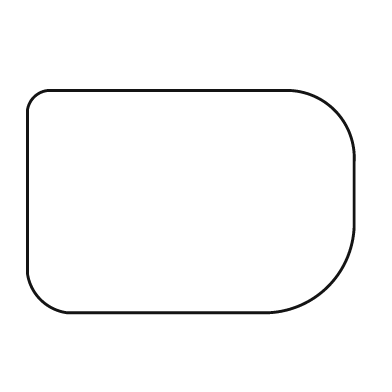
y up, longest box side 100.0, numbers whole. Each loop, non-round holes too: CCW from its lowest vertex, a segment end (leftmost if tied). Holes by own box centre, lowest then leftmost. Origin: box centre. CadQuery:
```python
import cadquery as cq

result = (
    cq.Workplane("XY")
    .moveTo(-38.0, -34.0)
    .lineTo(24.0, -34.0)
    .threePointArc((42.0, -26.0), (50.0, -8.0))
    .lineTo(50.0, 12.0)
    .threePointArc((44.0, 28.0), (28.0, 34.0))
    .lineTo(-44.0, 34.0)
    .threePointArc((-48.0, 32.0), (-50.0, 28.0))
    .lineTo(-50.0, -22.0)
    .threePointArc((-46.0, -30.0), (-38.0, -34.0))
    .close()
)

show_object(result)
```